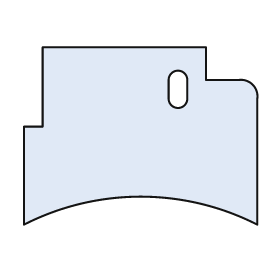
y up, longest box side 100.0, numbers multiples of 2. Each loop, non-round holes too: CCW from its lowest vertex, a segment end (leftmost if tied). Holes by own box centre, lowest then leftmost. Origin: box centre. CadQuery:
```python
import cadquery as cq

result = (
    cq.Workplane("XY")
    .moveTo(-50.0, -38.0)
    .threePointArc((0.0, -26.0), (50.0, -38.0))
    .lineTo(50.0, 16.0)
    .threePointArc((48.0, 22.0), (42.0, 24.0))
    .lineTo(28.0, 24.0)
    .lineTo(28.0, 38.0)
    .lineTo(-42.0, 38.0)
    .lineTo(-42.0, 4.0)
    .lineTo(-50.0, 4.0)
    .close()
    .moveTo(12.0, 16.0)
    .threePointArc((16.0, 12.0), (20.0, 16.0))
    .lineTo(20.0, 24.0)
    .threePointArc((16.0, 28.0), (12.0, 24.0))
    .close()
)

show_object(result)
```